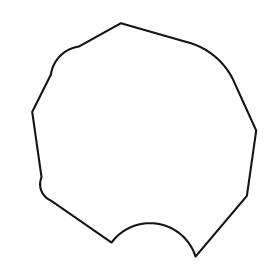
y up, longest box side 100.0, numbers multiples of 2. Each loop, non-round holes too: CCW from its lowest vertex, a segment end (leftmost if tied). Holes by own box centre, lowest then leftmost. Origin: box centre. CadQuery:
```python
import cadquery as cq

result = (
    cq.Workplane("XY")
    .moveTo(22.0, -50.0)
    .lineTo(44.0, -24.0)
    .lineTo(48.0, 4.0)
    .lineTo(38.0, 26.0)
    .threePointArc((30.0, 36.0), (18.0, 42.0))
    .lineTo(-10.0, 50.0)
    .lineTo(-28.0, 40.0)
    .threePointArc((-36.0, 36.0), (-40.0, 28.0))
    .lineTo(-48.0, 12.0)
    .lineTo(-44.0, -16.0)
    .threePointArc((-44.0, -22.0), (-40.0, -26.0))
    .lineTo(-14.0, -44.0)
    .threePointArc((6.0, -36.0), (22.0, -50.0))
    .close()
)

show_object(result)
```